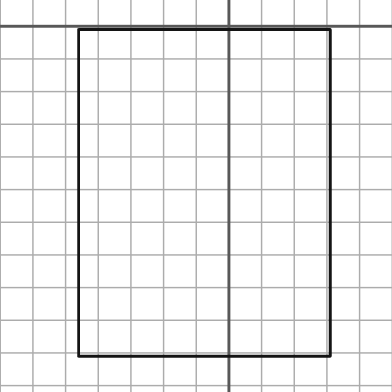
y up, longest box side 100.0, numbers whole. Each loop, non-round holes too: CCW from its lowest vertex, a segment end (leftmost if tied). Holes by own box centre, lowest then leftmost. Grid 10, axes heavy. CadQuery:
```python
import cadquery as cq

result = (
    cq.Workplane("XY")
    .moveTo(-46.0, -101.0)
    .lineTo(31.0, -101.0)
    .lineTo(31.0, -1.0)
    .lineTo(-46.0, -1.0)
    .close()
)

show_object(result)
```